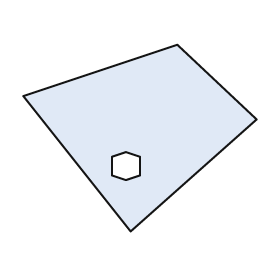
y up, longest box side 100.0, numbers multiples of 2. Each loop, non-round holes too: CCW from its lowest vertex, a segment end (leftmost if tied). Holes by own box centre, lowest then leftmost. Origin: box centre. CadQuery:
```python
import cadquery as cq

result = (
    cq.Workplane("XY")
    .moveTo(-4.0, -40.0)
    .lineTo(50.0, 8.0)
    .lineTo(16.0, 40.0)
    .lineTo(-50.0, 18.0)
    .close()
    .moveTo(-6.0, -18.0)
    .lineTo(0.0, -16.0)
    .lineTo(0.0, -8.0)
    .lineTo(-6.0, -6.0)
    .lineTo(-12.0, -8.0)
    .lineTo(-12.0, -16.0)
    .close()
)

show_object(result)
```